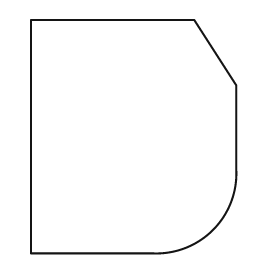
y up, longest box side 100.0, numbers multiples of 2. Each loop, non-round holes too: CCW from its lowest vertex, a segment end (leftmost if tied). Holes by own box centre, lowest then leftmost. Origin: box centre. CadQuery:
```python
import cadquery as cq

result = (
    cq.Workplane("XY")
    .moveTo(-44.0, -50.0)
    .lineTo(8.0, -50.0)
    .threePointArc((34.0, -40.0), (44.0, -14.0))
    .lineTo(44.0, 22.0)
    .lineTo(26.0, 50.0)
    .lineTo(-44.0, 50.0)
    .close()
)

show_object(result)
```